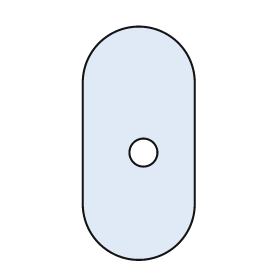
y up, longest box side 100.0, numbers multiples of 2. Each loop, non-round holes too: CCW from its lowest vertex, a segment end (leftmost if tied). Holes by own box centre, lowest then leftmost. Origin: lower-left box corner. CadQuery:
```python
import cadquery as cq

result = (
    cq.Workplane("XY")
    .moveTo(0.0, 24.0)
    .threePointArc((24.0, 0.0), (48.0, 24.0))
    .lineTo(48.0, 76.0)
    .threePointArc((24.0, 100.0), (0.0, 76.0))
    .close()
    .moveTo(26.0, 46.0)
    .circle(6.0)
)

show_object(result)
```